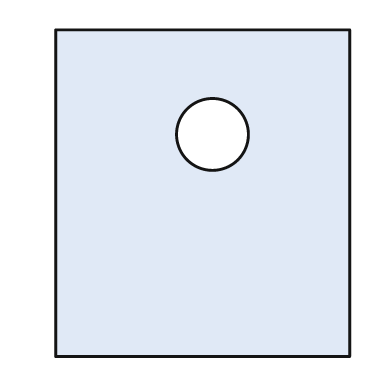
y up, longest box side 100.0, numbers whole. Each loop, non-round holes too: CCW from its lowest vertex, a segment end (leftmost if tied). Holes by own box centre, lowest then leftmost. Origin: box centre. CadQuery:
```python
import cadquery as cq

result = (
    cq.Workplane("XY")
    .moveTo(-45.0, -50.0)
    .lineTo(45.0, -50.0)
    .lineTo(45.0, 50.0)
    .lineTo(-45.0, 50.0)
    .close()
    .moveTo(3.0, 18.0)
    .circle(11.0)
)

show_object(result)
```